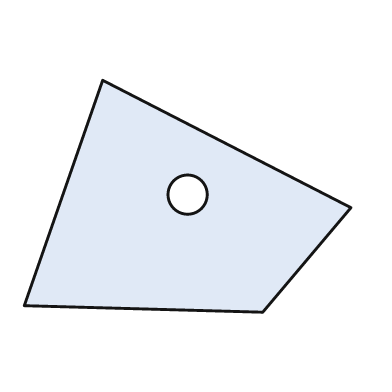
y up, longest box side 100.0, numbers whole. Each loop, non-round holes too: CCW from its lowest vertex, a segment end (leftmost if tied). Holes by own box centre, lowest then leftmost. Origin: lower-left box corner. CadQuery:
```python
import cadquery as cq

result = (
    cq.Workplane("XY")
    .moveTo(73.0, 0.0)
    .lineTo(100.0, 32.0)
    .lineTo(24.0, 71.0)
    .lineTo(0.0, 2.0)
    .close()
    .moveTo(50.0, 36.0)
    .circle(6.0)
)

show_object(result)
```